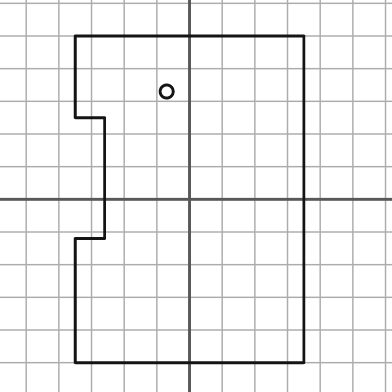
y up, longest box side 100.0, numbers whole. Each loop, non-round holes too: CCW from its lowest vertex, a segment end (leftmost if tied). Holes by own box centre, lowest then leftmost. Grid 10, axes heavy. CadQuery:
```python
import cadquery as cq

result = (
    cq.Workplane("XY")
    .moveTo(-35.0, -50.0)
    .lineTo(35.0, -50.0)
    .lineTo(35.0, 50.0)
    .lineTo(-35.0, 50.0)
    .lineTo(-35.0, 25.0)
    .lineTo(-26.0, 25.0)
    .lineTo(-26.0, -12.0)
    .lineTo(-35.0, -12.0)
    .close()
    .moveTo(-7.0, 33.0)
    .circle(2.0)
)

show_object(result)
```